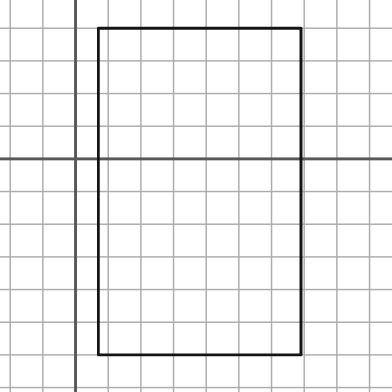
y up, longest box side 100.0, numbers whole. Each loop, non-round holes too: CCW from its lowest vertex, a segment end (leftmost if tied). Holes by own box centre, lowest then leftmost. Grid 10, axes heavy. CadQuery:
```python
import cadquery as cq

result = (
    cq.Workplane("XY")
    .moveTo(7.0, -60.0)
    .lineTo(69.0, -60.0)
    .lineTo(69.0, 40.0)
    .lineTo(7.0, 40.0)
    .close()
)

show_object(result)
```